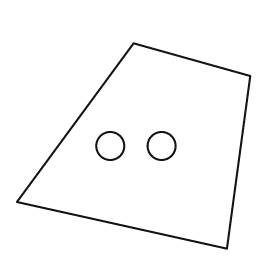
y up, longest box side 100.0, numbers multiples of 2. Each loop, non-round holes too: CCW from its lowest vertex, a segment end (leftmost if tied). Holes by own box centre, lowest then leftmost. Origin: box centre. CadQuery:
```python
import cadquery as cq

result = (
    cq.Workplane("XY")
    .moveTo(40.0, -44.0)
    .lineTo(50.0, 30.0)
    .lineTo(0.0, 44.0)
    .lineTo(-50.0, -24.0)
    .close()
    .moveTo(-10.0, 0.0)
    .circle(6.0)
    .moveTo(12.0, 0.0)
    .circle(6.0)
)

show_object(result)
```